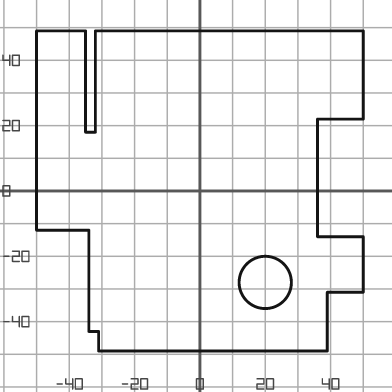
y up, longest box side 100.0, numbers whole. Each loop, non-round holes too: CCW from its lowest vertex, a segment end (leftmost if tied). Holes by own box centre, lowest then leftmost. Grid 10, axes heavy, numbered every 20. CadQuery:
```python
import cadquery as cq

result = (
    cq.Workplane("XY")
    .moveTo(-31.0, -49.0)
    .lineTo(39.0, -49.0)
    .lineTo(39.0, -31.0)
    .lineTo(50.0, -31.0)
    .lineTo(50.0, -14.0)
    .lineTo(36.0, -14.0)
    .lineTo(36.0, 22.0)
    .lineTo(50.0, 22.0)
    .lineTo(50.0, 49.0)
    .lineTo(-32.0, 49.0)
    .lineTo(-32.0, 18.0)
    .lineTo(-35.0, 18.0)
    .lineTo(-35.0, 49.0)
    .lineTo(-50.0, 49.0)
    .lineTo(-50.0, -12.0)
    .lineTo(-34.0, -12.0)
    .lineTo(-34.0, -43.0)
    .lineTo(-31.0, -43.0)
    .close()
    .moveTo(20.0, -28.0)
    .circle(8.0)
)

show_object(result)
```